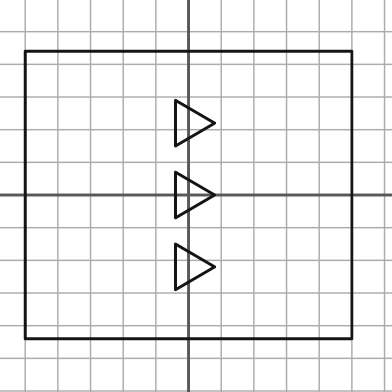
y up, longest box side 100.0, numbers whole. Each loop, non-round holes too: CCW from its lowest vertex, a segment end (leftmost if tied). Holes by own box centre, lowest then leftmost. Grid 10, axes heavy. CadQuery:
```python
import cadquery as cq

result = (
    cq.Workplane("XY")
    .moveTo(-50.0, -44.0)
    .lineTo(50.0, -44.0)
    .lineTo(50.0, 44.0)
    .lineTo(-50.0, 44.0)
    .close()
    .moveTo(-4.0, -29.0)
    .lineTo(8.0, -22.0)
    .lineTo(-4.0, -15.0)
    .close()
    .moveTo(-4.0, -7.0)
    .lineTo(8.0, 0.0)
    .lineTo(-4.0, 7.0)
    .close()
    .moveTo(-4.0, 15.0)
    .lineTo(8.0, 22.0)
    .lineTo(-4.0, 29.0)
    .close()
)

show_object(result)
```